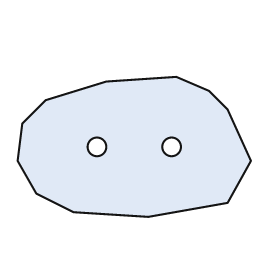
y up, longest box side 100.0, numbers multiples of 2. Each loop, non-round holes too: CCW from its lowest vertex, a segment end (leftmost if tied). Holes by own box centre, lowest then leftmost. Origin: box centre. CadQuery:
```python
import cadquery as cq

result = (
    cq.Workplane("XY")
    .moveTo(6.0, -30.0)
    .lineTo(40.0, -24.0)
    .lineTo(50.0, -6.0)
    .lineTo(40.0, 16.0)
    .lineTo(32.0, 24.0)
    .lineTo(18.0, 30.0)
    .lineTo(-12.0, 28.0)
    .lineTo(-38.0, 20.0)
    .lineTo(-48.0, 10.0)
    .lineTo(-50.0, -6.0)
    .lineTo(-42.0, -20.0)
    .lineTo(-26.0, -28.0)
    .close()
    .moveTo(-16.0, 0.0)
    .circle(4.0)
    .moveTo(16.0, 0.0)
    .circle(4.0)
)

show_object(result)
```